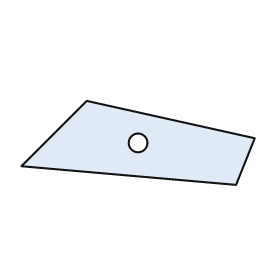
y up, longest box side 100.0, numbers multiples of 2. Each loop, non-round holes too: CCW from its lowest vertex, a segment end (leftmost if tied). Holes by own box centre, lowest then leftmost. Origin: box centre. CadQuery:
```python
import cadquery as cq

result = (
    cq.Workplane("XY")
    .moveTo(42.0, -18.0)
    .lineTo(50.0, 2.0)
    .lineTo(-22.0, 18.0)
    .lineTo(-50.0, -10.0)
    .close()
    .moveTo(0.0, 0.0)
    .circle(4.0)
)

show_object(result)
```